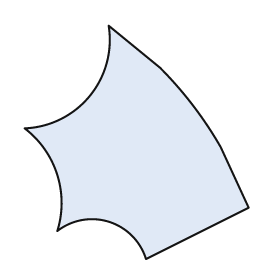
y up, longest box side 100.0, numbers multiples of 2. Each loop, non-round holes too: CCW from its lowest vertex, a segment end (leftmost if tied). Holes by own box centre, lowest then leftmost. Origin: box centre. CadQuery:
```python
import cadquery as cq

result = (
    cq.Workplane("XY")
    .moveTo(4.0, -50.0)
    .lineTo(48.0, -28.0)
    .lineTo(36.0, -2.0)
    .threePointArc((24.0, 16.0), (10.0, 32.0))
    .lineTo(-12.0, 50.0)
    .threePointArc((-20.0, 20.0), (-48.0, 6.0))
    .threePointArc((-34.0, -14.0), (-34.0, -38.0))
    .threePointArc((-12.0, -34.0), (4.0, -50.0))
    .close()
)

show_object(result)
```